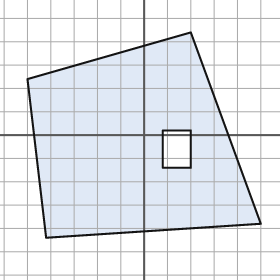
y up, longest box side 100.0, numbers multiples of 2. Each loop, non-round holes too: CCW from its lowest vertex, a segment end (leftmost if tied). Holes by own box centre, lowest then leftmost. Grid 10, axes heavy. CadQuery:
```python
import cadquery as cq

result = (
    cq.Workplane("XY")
    .moveTo(-42.0, -44.0)
    .lineTo(50.0, -38.0)
    .lineTo(20.0, 44.0)
    .lineTo(-50.0, 24.0)
    .close()
    .moveTo(8.0, -14.0)
    .lineTo(20.0, -14.0)
    .lineTo(20.0, 2.0)
    .lineTo(8.0, 2.0)
    .close()
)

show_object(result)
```